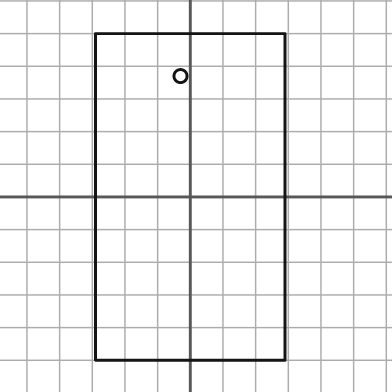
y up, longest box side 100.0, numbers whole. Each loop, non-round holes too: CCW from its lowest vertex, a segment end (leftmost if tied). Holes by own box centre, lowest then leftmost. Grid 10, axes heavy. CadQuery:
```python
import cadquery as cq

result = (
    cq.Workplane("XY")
    .moveTo(-29.0, -50.0)
    .lineTo(29.0, -50.0)
    .lineTo(29.0, 50.0)
    .lineTo(-29.0, 50.0)
    .close()
    .moveTo(-3.0, 37.0)
    .circle(2.0)
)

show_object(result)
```